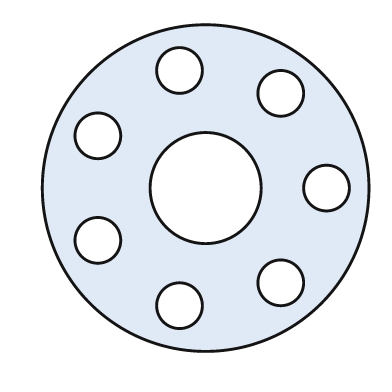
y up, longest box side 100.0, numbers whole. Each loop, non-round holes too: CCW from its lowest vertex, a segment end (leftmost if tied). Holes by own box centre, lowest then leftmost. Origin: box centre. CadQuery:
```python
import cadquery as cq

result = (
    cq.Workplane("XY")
    .moveTo(0.0, 0.0)
    .circle(50.0)
    .moveTo(-8.0, -36.0)
    .circle(7.0)
    .moveTo(23.0, -29.0)
    .circle(7.0)
    .moveTo(-33.0, -16.0)
    .circle(7.0)
    .moveTo(0.0, 0.0)
    .circle(17.0)
    .moveTo(37.0, 0.0)
    .circle(7.0)
    .moveTo(-33.0, 16.0)
    .circle(7.0)
    .moveTo(23.0, 29.0)
    .circle(7.0)
    .moveTo(-8.0, 36.0)
    .circle(7.0)
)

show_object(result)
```